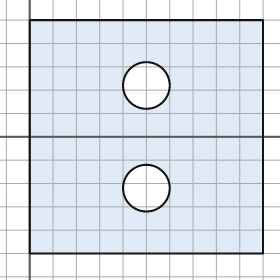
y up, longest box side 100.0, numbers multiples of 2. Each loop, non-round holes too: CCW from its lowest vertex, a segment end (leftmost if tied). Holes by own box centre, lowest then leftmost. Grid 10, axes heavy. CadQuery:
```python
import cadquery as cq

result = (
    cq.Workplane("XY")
    .moveTo(0.0, -50.0)
    .lineTo(100.0, -50.0)
    .lineTo(100.0, 50.0)
    .lineTo(0.0, 50.0)
    .close()
    .moveTo(50.0, -22.0)
    .circle(10.0)
    .moveTo(50.0, 22.0)
    .circle(10.0)
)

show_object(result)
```